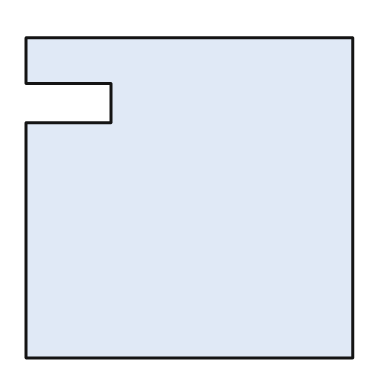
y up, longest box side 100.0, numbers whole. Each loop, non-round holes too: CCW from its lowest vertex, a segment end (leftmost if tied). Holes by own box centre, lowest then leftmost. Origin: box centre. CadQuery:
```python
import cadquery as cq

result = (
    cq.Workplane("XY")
    .moveTo(-50.0, -49.0)
    .lineTo(50.0, -49.0)
    .lineTo(50.0, 49.0)
    .lineTo(-50.0, 49.0)
    .lineTo(-50.0, 35.0)
    .lineTo(-24.0, 35.0)
    .lineTo(-24.0, 23.0)
    .lineTo(-50.0, 23.0)
    .close()
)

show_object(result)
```